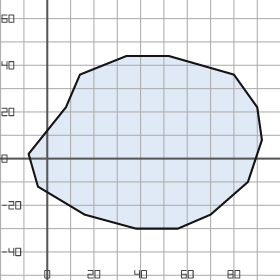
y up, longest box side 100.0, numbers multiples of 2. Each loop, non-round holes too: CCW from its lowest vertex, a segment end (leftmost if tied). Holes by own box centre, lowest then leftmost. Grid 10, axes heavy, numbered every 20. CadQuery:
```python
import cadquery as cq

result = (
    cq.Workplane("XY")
    .moveTo(38.0, -30.0)
    .lineTo(56.0, -30.0)
    .lineTo(70.0, -24.0)
    .lineTo(86.0, -10.0)
    .lineTo(92.0, 8.0)
    .lineTo(90.0, 22.0)
    .lineTo(80.0, 36.0)
    .lineTo(52.0, 44.0)
    .lineTo(34.0, 44.0)
    .lineTo(14.0, 36.0)
    .lineTo(8.0, 22.0)
    .lineTo(-8.0, 2.0)
    .lineTo(-4.0, -12.0)
    .lineTo(16.0, -24.0)
    .close()
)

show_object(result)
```